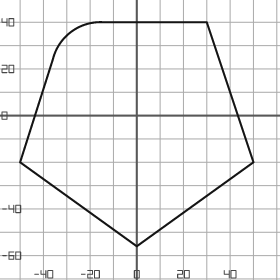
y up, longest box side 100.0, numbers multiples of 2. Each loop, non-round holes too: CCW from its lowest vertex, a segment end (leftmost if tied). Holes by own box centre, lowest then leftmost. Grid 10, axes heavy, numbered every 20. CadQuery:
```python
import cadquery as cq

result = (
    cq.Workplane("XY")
    .moveTo(0.0, -56.0)
    .lineTo(50.0, -20.0)
    .lineTo(30.0, 40.0)
    .lineTo(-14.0, 40.0)
    .threePointArc((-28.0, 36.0), (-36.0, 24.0))
    .lineTo(-50.0, -20.0)
    .close()
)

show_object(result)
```